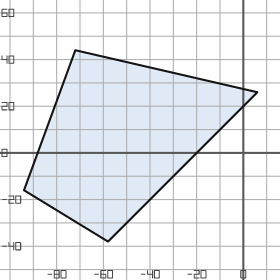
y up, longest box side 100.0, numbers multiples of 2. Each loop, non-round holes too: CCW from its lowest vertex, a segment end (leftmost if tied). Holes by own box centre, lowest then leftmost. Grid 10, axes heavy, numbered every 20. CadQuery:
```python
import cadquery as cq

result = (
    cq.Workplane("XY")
    .moveTo(-58.0, -38.0)
    .lineTo(6.0, 26.0)
    .lineTo(-72.0, 44.0)
    .lineTo(-94.0, -16.0)
    .close()
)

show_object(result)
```